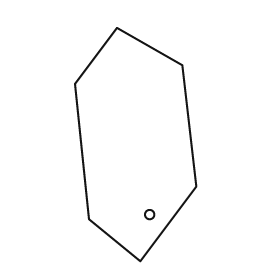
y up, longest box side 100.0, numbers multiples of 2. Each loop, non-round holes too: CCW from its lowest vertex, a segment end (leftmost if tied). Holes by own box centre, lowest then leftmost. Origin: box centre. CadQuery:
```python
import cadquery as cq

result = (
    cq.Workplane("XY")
    .moveTo(2.0, -50.0)
    .lineTo(26.0, -18.0)
    .lineTo(20.0, 34.0)
    .lineTo(-8.0, 50.0)
    .lineTo(-26.0, 26.0)
    .lineTo(-20.0, -32.0)
    .close()
    .moveTo(6.0, -30.0)
    .circle(2.0)
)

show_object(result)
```